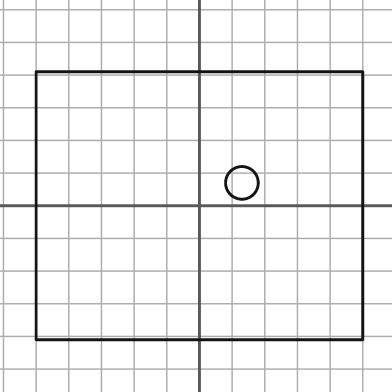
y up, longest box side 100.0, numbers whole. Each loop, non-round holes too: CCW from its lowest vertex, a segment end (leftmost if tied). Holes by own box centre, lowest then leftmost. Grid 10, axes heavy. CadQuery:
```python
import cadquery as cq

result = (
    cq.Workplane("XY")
    .moveTo(-50.0, -41.0)
    .lineTo(50.0, -41.0)
    .lineTo(50.0, 41.0)
    .lineTo(-50.0, 41.0)
    .close()
    .moveTo(13.0, 7.0)
    .circle(5.0)
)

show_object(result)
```